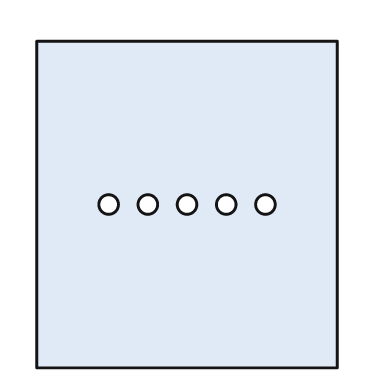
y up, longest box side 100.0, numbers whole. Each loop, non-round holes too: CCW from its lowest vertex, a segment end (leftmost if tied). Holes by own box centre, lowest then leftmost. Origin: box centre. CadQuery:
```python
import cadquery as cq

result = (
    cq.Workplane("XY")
    .moveTo(-46.0, -50.0)
    .lineTo(46.0, -50.0)
    .lineTo(46.0, 50.0)
    .lineTo(-46.0, 50.0)
    .close()
    .moveTo(-24.0, 0.0)
    .circle(3.0)
    .moveTo(-12.0, 0.0)
    .circle(3.0)
    .moveTo(0.0, 0.0)
    .circle(3.0)
    .moveTo(12.0, 0.0)
    .circle(3.0)
    .moveTo(24.0, 0.0)
    .circle(3.0)
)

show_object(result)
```